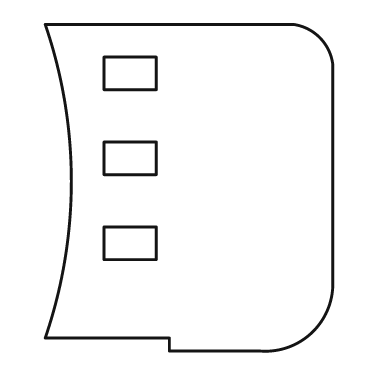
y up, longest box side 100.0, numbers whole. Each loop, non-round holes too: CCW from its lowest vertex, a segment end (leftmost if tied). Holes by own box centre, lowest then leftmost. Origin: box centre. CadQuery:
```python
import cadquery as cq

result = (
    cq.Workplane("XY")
    .moveTo(-6.0, -50.0)
    .lineTo(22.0, -50.0)
    .threePointArc((38.0, -44.0), (44.0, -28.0))
    .lineTo(44.0, 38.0)
    .threePointArc((40.0, 46.0), (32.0, 50.0))
    .lineTo(-44.0, 50.0)
    .threePointArc((-36.0, 2.0), (-44.0, -46.0))
    .lineTo(-6.0, -46.0)
    .close()
    .moveTo(-26.0, -22.0)
    .lineTo(-10.0, -22.0)
    .lineTo(-10.0, -12.0)
    .lineTo(-26.0, -12.0)
    .close()
    .moveTo(-26.0, 4.0)
    .lineTo(-10.0, 4.0)
    .lineTo(-10.0, 14.0)
    .lineTo(-26.0, 14.0)
    .close()
    .moveTo(-26.0, 30.0)
    .lineTo(-10.0, 30.0)
    .lineTo(-10.0, 40.0)
    .lineTo(-26.0, 40.0)
    .close()
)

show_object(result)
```